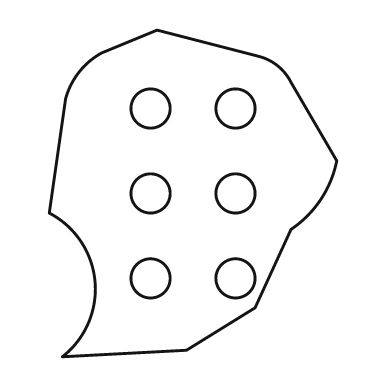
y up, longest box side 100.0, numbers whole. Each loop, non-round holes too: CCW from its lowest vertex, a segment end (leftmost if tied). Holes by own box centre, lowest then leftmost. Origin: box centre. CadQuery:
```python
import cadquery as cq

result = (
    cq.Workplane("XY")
    .moveTo(-40.0, -50.0)
    .lineTo(-2.0, -48.0)
    .lineTo(19.0, -35.0)
    .lineTo(30.0, -11.0)
    .threePointArc((39.0, -2.0), (44.0, 10.0))
    .lineTo(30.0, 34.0)
    .threePointArc((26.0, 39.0), (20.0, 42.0))
    .lineTo(-11.0, 50.0)
    .lineTo(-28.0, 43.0)
    .threePointArc((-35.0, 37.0), (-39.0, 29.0))
    .lineTo(-44.0, -6.0)
    .threePointArc((-30.0, -27.0), (-40.0, -50.0))
    .close()
    .moveTo(-13.0, -26.0)
    .circle(6.0)
    .moveTo(13.0, -26.0)
    .circle(6.0)
    .moveTo(-13.0, 0.0)
    .circle(6.0)
    .moveTo(13.0, 0.0)
    .circle(6.0)
    .moveTo(-13.0, 26.0)
    .circle(6.0)
    .moveTo(13.0, 26.0)
    .circle(6.0)
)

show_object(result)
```